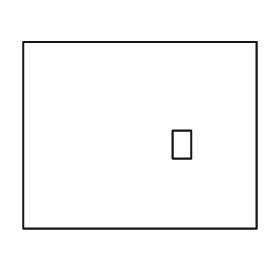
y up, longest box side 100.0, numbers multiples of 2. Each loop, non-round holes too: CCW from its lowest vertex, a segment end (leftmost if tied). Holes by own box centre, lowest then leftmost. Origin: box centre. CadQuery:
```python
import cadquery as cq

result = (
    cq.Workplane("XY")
    .moveTo(-50.0, -40.0)
    .lineTo(50.0, -40.0)
    .lineTo(50.0, 40.0)
    .lineTo(-50.0, 40.0)
    .close()
    .moveTo(14.0, -10.0)
    .lineTo(22.0, -10.0)
    .lineTo(22.0, 2.0)
    .lineTo(14.0, 2.0)
    .close()
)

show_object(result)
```